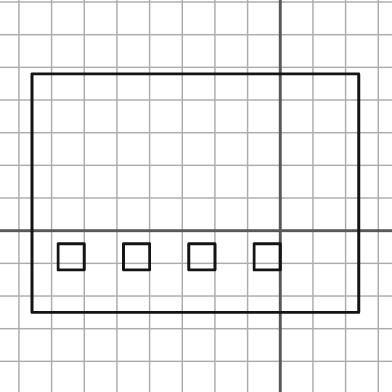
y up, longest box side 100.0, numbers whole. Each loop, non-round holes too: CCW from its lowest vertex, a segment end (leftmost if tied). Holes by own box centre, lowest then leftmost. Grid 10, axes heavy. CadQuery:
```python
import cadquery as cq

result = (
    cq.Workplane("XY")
    .moveTo(-76.0, -25.0)
    .lineTo(24.0, -25.0)
    .lineTo(24.0, 48.0)
    .lineTo(-76.0, 48.0)
    .close()
    .moveTo(-68.0, -12.0)
    .lineTo(-60.0, -12.0)
    .lineTo(-60.0, -4.0)
    .lineTo(-68.0, -4.0)
    .close()
    .moveTo(-48.0, -12.0)
    .lineTo(-40.0, -12.0)
    .lineTo(-40.0, -4.0)
    .lineTo(-48.0, -4.0)
    .close()
    .moveTo(-28.0, -12.0)
    .lineTo(-20.0, -12.0)
    .lineTo(-20.0, -4.0)
    .lineTo(-28.0, -4.0)
    .close()
    .moveTo(-8.0, -12.0)
    .lineTo(0.0, -12.0)
    .lineTo(0.0, -4.0)
    .lineTo(-8.0, -4.0)
    .close()
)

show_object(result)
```